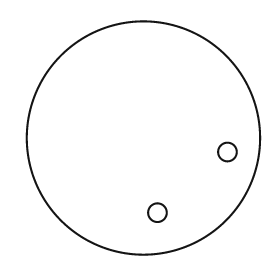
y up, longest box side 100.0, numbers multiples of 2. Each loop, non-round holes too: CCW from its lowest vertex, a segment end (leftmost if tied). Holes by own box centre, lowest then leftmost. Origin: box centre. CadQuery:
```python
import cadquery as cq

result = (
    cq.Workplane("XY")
    .moveTo(0.0, 0.0)
    .circle(50.0)
    .moveTo(6.0, -32.0)
    .circle(4.0)
    .moveTo(36.0, -6.0)
    .circle(4.0)
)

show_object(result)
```